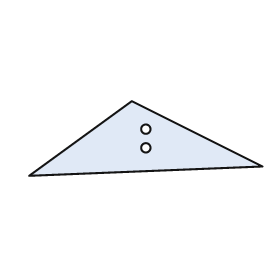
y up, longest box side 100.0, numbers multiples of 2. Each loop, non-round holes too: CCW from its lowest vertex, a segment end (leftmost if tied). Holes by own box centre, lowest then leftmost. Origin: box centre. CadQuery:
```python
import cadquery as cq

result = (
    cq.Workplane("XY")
    .moveTo(-50.0, -16.0)
    .lineTo(50.0, -12.0)
    .lineTo(-6.0, 16.0)
    .close()
    .moveTo(0.0, -4.0)
    .circle(2.0)
    .moveTo(0.0, 4.0)
    .circle(2.0)
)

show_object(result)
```